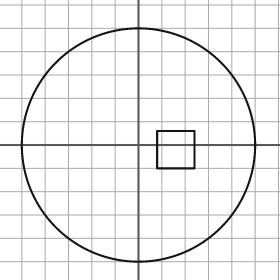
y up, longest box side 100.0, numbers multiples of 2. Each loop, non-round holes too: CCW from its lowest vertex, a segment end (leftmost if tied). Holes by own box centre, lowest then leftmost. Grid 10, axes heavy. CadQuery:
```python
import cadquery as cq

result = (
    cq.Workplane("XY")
    .moveTo(0.0, 0.0)
    .circle(50.0)
    .moveTo(8.0, -10.0)
    .lineTo(24.0, -10.0)
    .lineTo(24.0, 6.0)
    .lineTo(8.0, 6.0)
    .close()
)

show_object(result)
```